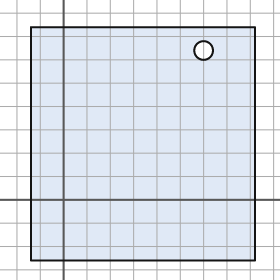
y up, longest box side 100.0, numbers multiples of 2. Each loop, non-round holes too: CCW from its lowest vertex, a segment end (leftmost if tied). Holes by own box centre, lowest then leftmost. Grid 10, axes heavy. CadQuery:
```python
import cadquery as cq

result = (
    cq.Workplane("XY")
    .moveTo(-14.0, -26.0)
    .lineTo(82.0, -26.0)
    .lineTo(82.0, 74.0)
    .lineTo(-14.0, 74.0)
    .close()
    .moveTo(60.0, 64.0)
    .circle(4.0)
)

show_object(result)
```